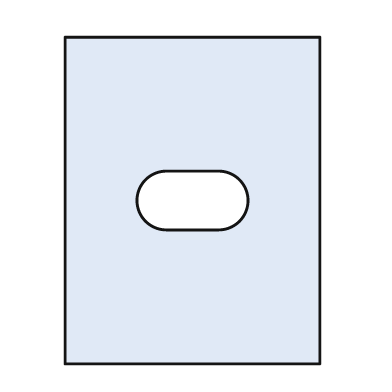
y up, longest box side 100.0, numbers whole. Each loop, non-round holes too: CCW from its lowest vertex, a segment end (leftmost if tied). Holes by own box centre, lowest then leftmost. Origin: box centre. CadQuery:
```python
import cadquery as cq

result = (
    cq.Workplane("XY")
    .moveTo(-39.0, -50.0)
    .lineTo(39.0, -50.0)
    .lineTo(39.0, 50.0)
    .lineTo(-39.0, 50.0)
    .close()
    .moveTo(-8.0, -9.0)
    .lineTo(8.0, -9.0)
    .threePointArc((17.0, 0.0), (8.0, 9.0))
    .lineTo(-8.0, 9.0)
    .threePointArc((-17.0, 0.0), (-8.0, -9.0))
    .close()
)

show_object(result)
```